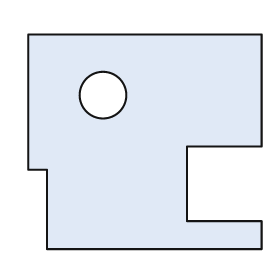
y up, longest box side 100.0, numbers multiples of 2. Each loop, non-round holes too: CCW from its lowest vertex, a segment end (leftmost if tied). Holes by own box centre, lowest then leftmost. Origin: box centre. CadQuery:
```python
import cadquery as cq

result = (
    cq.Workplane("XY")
    .moveTo(-42.0, -46.0)
    .lineTo(50.0, -46.0)
    .lineTo(50.0, -34.0)
    .lineTo(18.0, -34.0)
    .lineTo(18.0, -2.0)
    .lineTo(50.0, -2.0)
    .lineTo(50.0, 46.0)
    .lineTo(-50.0, 46.0)
    .lineTo(-50.0, -12.0)
    .lineTo(-42.0, -12.0)
    .close()
    .moveTo(-18.0, 20.0)
    .circle(10.0)
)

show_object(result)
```